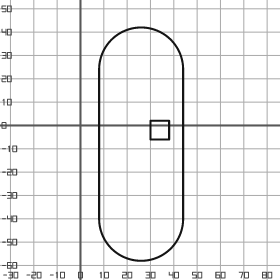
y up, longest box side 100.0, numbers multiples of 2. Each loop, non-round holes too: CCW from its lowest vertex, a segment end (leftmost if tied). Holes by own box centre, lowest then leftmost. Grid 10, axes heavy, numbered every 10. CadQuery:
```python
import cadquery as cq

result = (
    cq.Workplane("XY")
    .moveTo(8.0, -40.0)
    .threePointArc((26.0, -58.0), (44.0, -40.0))
    .lineTo(44.0, 24.0)
    .threePointArc((26.0, 42.0), (8.0, 24.0))
    .close()
    .moveTo(30.0, -6.0)
    .lineTo(38.0, -6.0)
    .lineTo(38.0, 2.0)
    .lineTo(30.0, 2.0)
    .close()
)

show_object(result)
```